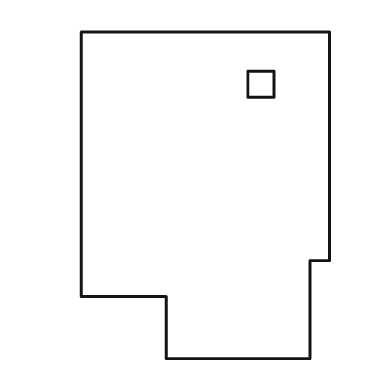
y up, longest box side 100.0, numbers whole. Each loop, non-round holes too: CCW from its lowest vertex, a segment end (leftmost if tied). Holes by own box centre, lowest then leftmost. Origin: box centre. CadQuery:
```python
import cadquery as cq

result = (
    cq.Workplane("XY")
    .moveTo(-12.0, -50.0)
    .lineTo(32.0, -50.0)
    .lineTo(32.0, -20.0)
    .lineTo(38.0, -20.0)
    .lineTo(38.0, 50.0)
    .lineTo(-38.0, 50.0)
    .lineTo(-38.0, -31.0)
    .lineTo(-12.0, -31.0)
    .close()
    .moveTo(13.0, 30.0)
    .lineTo(21.0, 30.0)
    .lineTo(21.0, 38.0)
    .lineTo(13.0, 38.0)
    .close()
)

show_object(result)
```